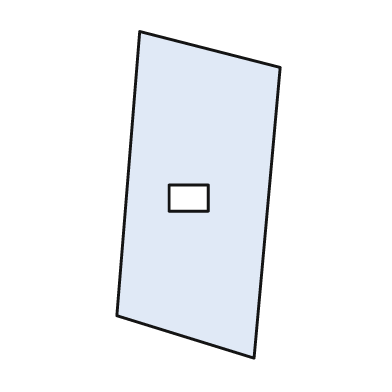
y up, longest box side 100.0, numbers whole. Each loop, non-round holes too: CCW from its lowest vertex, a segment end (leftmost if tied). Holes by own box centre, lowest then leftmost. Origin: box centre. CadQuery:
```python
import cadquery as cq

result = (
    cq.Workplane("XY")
    .moveTo(17.0, -50.0)
    .lineTo(25.0, 39.0)
    .lineTo(-18.0, 50.0)
    .lineTo(-25.0, -37.0)
    .close()
    .moveTo(-9.0, -5.0)
    .lineTo(3.0, -5.0)
    .lineTo(3.0, 3.0)
    .lineTo(-9.0, 3.0)
    .close()
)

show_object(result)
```